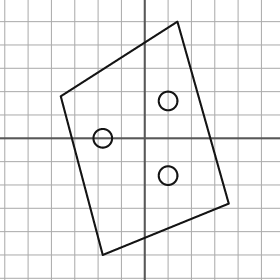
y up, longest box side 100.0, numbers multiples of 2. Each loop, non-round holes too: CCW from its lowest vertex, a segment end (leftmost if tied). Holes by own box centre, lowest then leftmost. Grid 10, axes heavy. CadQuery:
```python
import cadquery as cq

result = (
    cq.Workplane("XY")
    .moveTo(-18.0, -50.0)
    .lineTo(36.0, -28.0)
    .lineTo(14.0, 50.0)
    .lineTo(-36.0, 18.0)
    .close()
    .moveTo(10.0, -16.0)
    .circle(4.0)
    .moveTo(-18.0, 0.0)
    .circle(4.0)
    .moveTo(10.0, 16.0)
    .circle(4.0)
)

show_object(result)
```